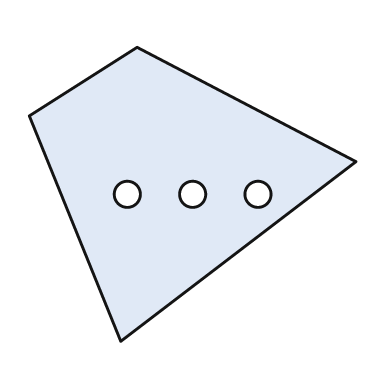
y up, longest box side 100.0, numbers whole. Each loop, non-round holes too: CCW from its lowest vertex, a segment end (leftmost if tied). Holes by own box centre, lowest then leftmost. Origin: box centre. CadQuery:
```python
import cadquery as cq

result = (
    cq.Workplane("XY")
    .moveTo(-22.0, -45.0)
    .lineTo(50.0, 10.0)
    .lineTo(-17.0, 45.0)
    .lineTo(-50.0, 24.0)
    .close()
    .moveTo(-20.0, 0.0)
    .circle(4.0)
    .moveTo(0.0, 0.0)
    .circle(4.0)
    .moveTo(20.0, 0.0)
    .circle(4.0)
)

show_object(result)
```